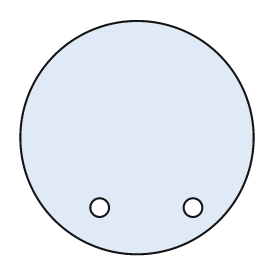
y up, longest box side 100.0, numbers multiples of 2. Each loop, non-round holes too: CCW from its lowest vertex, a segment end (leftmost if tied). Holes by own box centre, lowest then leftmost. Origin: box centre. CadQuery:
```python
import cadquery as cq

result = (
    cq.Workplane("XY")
    .moveTo(0.0, 0.0)
    .circle(50.0)
    .moveTo(-16.0, -30.0)
    .circle(4.0)
    .moveTo(24.0, -30.0)
    .circle(4.0)
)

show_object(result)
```